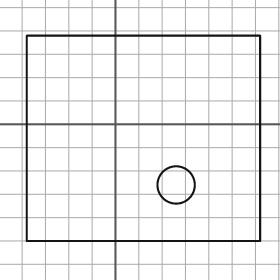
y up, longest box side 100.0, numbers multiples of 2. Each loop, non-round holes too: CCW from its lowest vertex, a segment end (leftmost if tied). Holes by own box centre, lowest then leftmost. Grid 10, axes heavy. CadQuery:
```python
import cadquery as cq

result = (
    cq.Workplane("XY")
    .moveTo(-38.0, -50.0)
    .lineTo(62.0, -50.0)
    .lineTo(62.0, 38.0)
    .lineTo(-38.0, 38.0)
    .close()
    .moveTo(26.0, -26.0)
    .circle(8.0)
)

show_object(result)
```